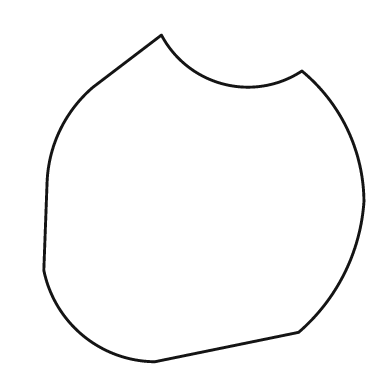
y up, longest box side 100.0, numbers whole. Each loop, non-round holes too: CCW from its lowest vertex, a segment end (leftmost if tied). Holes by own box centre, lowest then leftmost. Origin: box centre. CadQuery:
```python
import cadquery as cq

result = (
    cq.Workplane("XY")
    .moveTo(-15.0, -50.0)
    .lineTo(29.0, -41.0)
    .threePointArc((43.0, -23.0), (49.0, -1.0))
    .threePointArc((44.0, 21.0), (30.0, 39.0))
    .threePointArc((6.0, 35.0), (-13.0, 50.0))
    .lineTo(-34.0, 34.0)
    .threePointArc((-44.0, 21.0), (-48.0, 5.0))
    .lineTo(-49.0, -22.0)
    .threePointArc((-37.0, -42.0), (-15.0, -50.0))
    .close()
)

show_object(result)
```